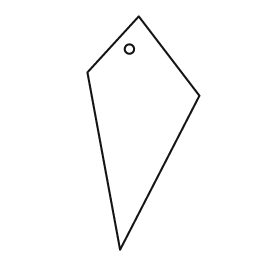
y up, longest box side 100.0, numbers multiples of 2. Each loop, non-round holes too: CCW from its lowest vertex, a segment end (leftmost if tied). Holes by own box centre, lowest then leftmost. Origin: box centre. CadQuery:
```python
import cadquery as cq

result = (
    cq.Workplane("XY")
    .moveTo(-10.0, -50.0)
    .lineTo(24.0, 16.0)
    .lineTo(-2.0, 50.0)
    .lineTo(-24.0, 26.0)
    .close()
    .moveTo(-6.0, 36.0)
    .circle(2.0)
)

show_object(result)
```